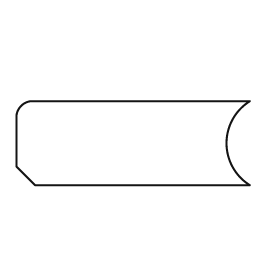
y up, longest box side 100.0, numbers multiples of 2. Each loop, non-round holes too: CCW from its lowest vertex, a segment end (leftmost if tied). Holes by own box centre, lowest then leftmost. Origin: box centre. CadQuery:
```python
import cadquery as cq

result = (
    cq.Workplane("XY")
    .moveTo(-42.0, -18.0)
    .lineTo(50.0, -18.0)
    .threePointArc((40.0, 0.0), (50.0, 18.0))
    .lineTo(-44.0, 18.0)
    .threePointArc((-48.0, 16.0), (-50.0, 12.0))
    .lineTo(-50.0, -10.0)
    .close()
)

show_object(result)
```